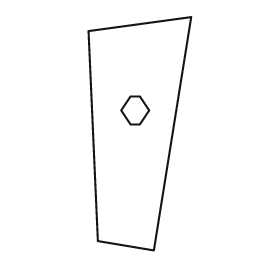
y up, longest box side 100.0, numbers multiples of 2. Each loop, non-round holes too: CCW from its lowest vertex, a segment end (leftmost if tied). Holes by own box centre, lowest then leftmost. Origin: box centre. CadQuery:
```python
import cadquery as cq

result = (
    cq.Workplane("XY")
    .moveTo(6.0, -50.0)
    .lineTo(22.0, 50.0)
    .lineTo(-22.0, 44.0)
    .lineTo(-18.0, -46.0)
    .close()
    .moveTo(-4.0, 4.0)
    .lineTo(0.0, 4.0)
    .lineTo(4.0, 10.0)
    .lineTo(0.0, 16.0)
    .lineTo(-4.0, 16.0)
    .lineTo(-8.0, 10.0)
    .close()
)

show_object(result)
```